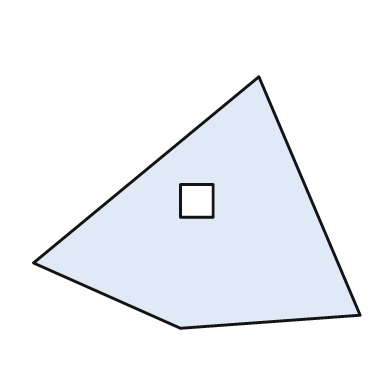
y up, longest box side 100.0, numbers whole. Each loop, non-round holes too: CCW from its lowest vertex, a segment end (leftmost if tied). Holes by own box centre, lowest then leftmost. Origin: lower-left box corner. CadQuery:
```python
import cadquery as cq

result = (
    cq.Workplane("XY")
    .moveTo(45.0, 0.0)
    .lineTo(100.0, 4.0)
    .lineTo(69.0, 77.0)
    .lineTo(0.0, 20.0)
    .close()
    .moveTo(45.0, 34.0)
    .lineTo(55.0, 34.0)
    .lineTo(55.0, 44.0)
    .lineTo(45.0, 44.0)
    .close()
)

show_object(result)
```